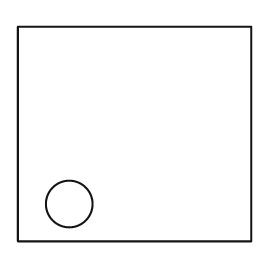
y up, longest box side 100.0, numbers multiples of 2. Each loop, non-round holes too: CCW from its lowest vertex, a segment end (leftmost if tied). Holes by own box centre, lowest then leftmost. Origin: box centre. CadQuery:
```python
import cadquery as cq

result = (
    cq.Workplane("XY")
    .moveTo(-50.0, -46.0)
    .lineTo(50.0, -46.0)
    .lineTo(50.0, 46.0)
    .lineTo(-50.0, 46.0)
    .close()
    .moveTo(-28.0, -30.0)
    .circle(10.0)
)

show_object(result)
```